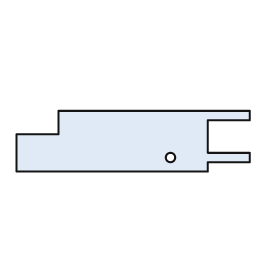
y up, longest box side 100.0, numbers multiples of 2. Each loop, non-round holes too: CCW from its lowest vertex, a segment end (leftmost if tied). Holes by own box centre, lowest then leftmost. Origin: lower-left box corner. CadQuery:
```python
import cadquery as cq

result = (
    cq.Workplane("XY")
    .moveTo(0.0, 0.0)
    .lineTo(82.0, 0.0)
    .lineTo(82.0, 4.0)
    .lineTo(100.0, 4.0)
    .lineTo(100.0, 8.0)
    .lineTo(82.0, 8.0)
    .lineTo(82.0, 22.0)
    .lineTo(100.0, 22.0)
    .lineTo(100.0, 26.0)
    .lineTo(18.0, 26.0)
    .lineTo(18.0, 16.0)
    .lineTo(0.0, 16.0)
    .close()
    .moveTo(66.0, 6.0)
    .circle(2.0)
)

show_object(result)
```